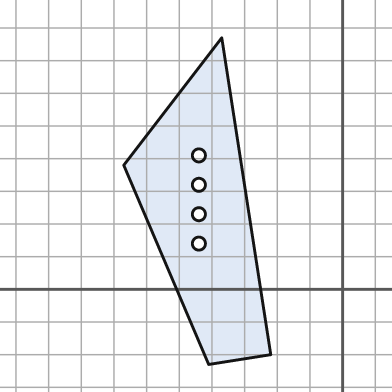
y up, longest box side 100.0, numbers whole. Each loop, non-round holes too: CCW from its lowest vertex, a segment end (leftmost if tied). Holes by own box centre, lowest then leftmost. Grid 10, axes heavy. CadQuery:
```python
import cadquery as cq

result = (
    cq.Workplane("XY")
    .moveTo(-41.0, -23.0)
    .lineTo(-22.0, -20.0)
    .lineTo(-37.0, 77.0)
    .lineTo(-67.0, 38.0)
    .close()
    .moveTo(-44.0, 14.0)
    .circle(2.0)
    .moveTo(-44.0, 23.0)
    .circle(2.0)
    .moveTo(-44.0, 32.0)
    .circle(2.0)
    .moveTo(-44.0, 41.0)
    .circle(2.0)
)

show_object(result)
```